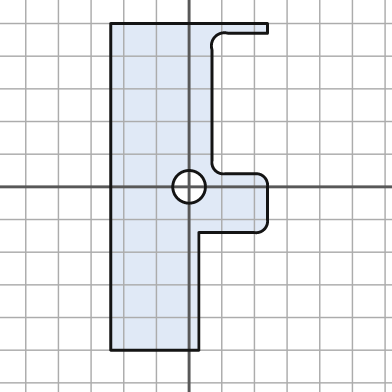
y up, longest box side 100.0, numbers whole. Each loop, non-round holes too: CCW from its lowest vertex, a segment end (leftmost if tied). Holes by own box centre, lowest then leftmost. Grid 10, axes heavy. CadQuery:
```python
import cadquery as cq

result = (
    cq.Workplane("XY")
    .moveTo(-24.0, -50.0)
    .lineTo(3.0, -50.0)
    .lineTo(3.0, -14.0)
    .lineTo(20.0, -14.0)
    .threePointArc((23.0, -13.0), (24.0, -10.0))
    .lineTo(24.0, 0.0)
    .threePointArc((23.0, 3.0), (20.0, 4.0))
    .lineTo(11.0, 4.0)
    .threePointArc((8.0, 5.0), (7.0, 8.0))
    .lineTo(7.0, 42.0)
    .threePointArc((8.0, 46.0), (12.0, 47.0))
    .lineTo(24.0, 47.0)
    .lineTo(24.0, 50.0)
    .lineTo(-24.0, 50.0)
    .close()
    .moveTo(0.0, 0.0)
    .circle(5.0)
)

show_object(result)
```